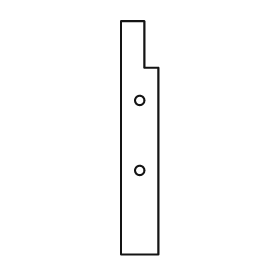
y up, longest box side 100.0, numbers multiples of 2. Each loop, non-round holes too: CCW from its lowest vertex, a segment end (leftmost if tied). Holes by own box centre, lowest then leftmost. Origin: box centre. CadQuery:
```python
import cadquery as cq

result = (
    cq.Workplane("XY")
    .moveTo(-8.0, -50.0)
    .lineTo(8.0, -50.0)
    .lineTo(8.0, 30.0)
    .lineTo(2.0, 30.0)
    .lineTo(2.0, 50.0)
    .lineTo(-8.0, 50.0)
    .close()
    .moveTo(0.0, -14.0)
    .circle(2.0)
    .moveTo(0.0, 16.0)
    .circle(2.0)
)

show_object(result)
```